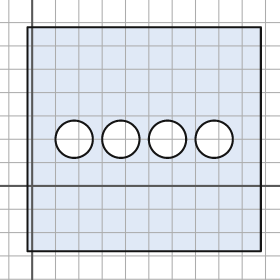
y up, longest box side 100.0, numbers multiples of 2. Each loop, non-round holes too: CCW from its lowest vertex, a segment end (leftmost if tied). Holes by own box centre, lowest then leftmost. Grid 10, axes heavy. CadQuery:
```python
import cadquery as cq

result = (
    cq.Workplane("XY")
    .moveTo(-2.0, -28.0)
    .lineTo(98.0, -28.0)
    .lineTo(98.0, 68.0)
    .lineTo(-2.0, 68.0)
    .close()
    .moveTo(18.0, 20.0)
    .circle(8.0)
    .moveTo(38.0, 20.0)
    .circle(8.0)
    .moveTo(58.0, 20.0)
    .circle(8.0)
    .moveTo(78.0, 20.0)
    .circle(8.0)
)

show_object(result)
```